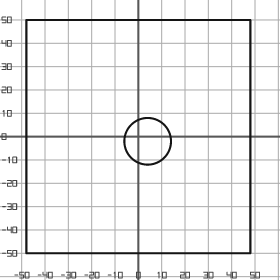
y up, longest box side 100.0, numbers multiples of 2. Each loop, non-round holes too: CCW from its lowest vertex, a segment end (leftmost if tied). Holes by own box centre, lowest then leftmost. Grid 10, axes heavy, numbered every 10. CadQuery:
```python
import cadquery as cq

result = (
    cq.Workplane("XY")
    .moveTo(-48.0, -50.0)
    .lineTo(48.0, -50.0)
    .lineTo(48.0, 50.0)
    .lineTo(-48.0, 50.0)
    .close()
    .moveTo(4.0, -2.0)
    .circle(10.0)
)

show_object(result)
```